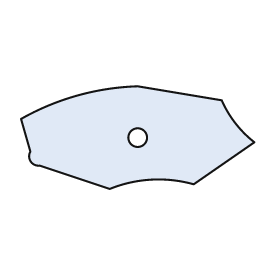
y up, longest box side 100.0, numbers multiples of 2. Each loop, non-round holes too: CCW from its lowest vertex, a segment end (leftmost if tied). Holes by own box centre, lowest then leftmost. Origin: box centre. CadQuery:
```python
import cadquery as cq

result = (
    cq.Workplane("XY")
    .moveTo(-12.0, -22.0)
    .threePointArc((6.0, -18.0), (24.0, -20.0))
    .lineTo(50.0, -2.0)
    .threePointArc((42.0, 6.0), (36.0, 16.0))
    .lineTo(0.0, 22.0)
    .threePointArc((-26.0, 18.0), (-50.0, 8.0))
    .lineTo(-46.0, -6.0)
    .threePointArc((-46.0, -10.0), (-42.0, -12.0))
    .close()
    .moveTo(0.0, 0.0)
    .circle(4.0)
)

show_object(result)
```